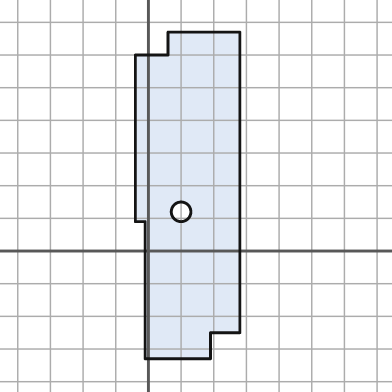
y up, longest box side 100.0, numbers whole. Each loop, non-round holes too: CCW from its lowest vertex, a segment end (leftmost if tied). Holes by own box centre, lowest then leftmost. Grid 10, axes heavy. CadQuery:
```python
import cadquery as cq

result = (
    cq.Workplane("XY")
    .moveTo(-1.0, -33.0)
    .lineTo(19.0, -33.0)
    .lineTo(19.0, -25.0)
    .lineTo(28.0, -25.0)
    .lineTo(28.0, 67.0)
    .lineTo(6.0, 67.0)
    .lineTo(6.0, 60.0)
    .lineTo(-4.0, 60.0)
    .lineTo(-4.0, 9.0)
    .lineTo(-1.0, 9.0)
    .close()
    .moveTo(10.0, 12.0)
    .circle(3.0)
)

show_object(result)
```